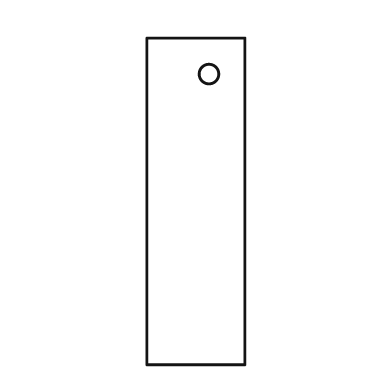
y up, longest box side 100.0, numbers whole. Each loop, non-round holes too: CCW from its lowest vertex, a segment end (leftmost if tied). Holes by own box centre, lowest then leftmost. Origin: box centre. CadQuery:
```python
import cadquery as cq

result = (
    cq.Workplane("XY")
    .moveTo(-15.0, -50.0)
    .lineTo(15.0, -50.0)
    .lineTo(15.0, 50.0)
    .lineTo(-15.0, 50.0)
    .close()
    .moveTo(4.0, 39.0)
    .circle(3.0)
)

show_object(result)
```